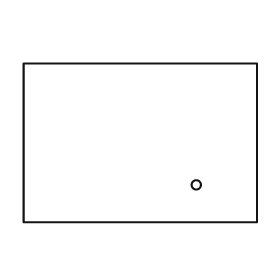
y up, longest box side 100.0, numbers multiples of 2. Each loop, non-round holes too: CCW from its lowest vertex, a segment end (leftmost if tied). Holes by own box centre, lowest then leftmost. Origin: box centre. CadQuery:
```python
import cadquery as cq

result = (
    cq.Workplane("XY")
    .moveTo(-50.0, -34.0)
    .lineTo(50.0, -34.0)
    .lineTo(50.0, 34.0)
    .lineTo(-50.0, 34.0)
    .close()
    .moveTo(24.0, -18.0)
    .circle(2.0)
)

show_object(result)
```